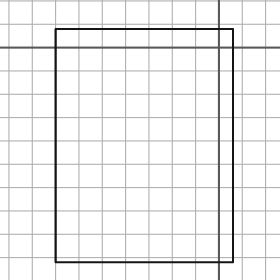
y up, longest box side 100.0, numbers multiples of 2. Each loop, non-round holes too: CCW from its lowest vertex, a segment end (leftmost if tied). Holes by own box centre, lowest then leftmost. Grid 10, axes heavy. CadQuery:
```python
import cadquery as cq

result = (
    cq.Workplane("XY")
    .moveTo(-70.0, -92.0)
    .lineTo(6.0, -92.0)
    .lineTo(6.0, 8.0)
    .lineTo(-70.0, 8.0)
    .close()
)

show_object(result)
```